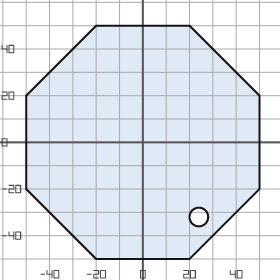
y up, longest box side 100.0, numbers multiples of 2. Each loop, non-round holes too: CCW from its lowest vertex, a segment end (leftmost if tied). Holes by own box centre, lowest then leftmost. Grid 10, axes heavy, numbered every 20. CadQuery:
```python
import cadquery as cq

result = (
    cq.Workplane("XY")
    .moveTo(-20.0, -50.0)
    .lineTo(20.0, -50.0)
    .lineTo(50.0, -20.0)
    .lineTo(50.0, 20.0)
    .lineTo(20.0, 50.0)
    .lineTo(-20.0, 50.0)
    .lineTo(-50.0, 20.0)
    .lineTo(-50.0, -20.0)
    .close()
    .moveTo(24.0, -32.0)
    .circle(4.0)
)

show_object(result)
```